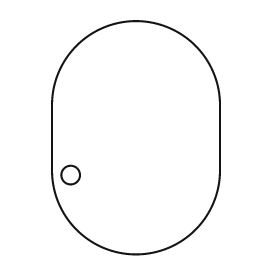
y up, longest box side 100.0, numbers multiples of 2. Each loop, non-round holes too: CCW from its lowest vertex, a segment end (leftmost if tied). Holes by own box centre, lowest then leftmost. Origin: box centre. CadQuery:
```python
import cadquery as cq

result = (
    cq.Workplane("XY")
    .moveTo(-36.0, -14.0)
    .threePointArc((0.0, -50.0), (36.0, -14.0))
    .lineTo(36.0, 14.0)
    .threePointArc((0.0, 50.0), (-36.0, 14.0))
    .close()
    .moveTo(-28.0, -16.0)
    .circle(4.0)
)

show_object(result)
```